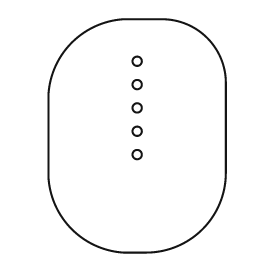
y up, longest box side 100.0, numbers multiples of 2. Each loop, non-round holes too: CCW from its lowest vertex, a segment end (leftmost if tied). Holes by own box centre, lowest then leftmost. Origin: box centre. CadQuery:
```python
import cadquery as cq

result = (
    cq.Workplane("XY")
    .moveTo(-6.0, -50.0)
    .lineTo(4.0, -50.0)
    .threePointArc((28.0, -40.0), (38.0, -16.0))
    .lineTo(38.0, 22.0)
    .threePointArc((30.0, 42.0), (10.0, 50.0))
    .lineTo(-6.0, 50.0)
    .threePointArc((-28.0, 40.0), (-38.0, 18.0))
    .lineTo(-38.0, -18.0)
    .threePointArc((-28.0, -40.0), (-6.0, -50.0))
    .close()
    .moveTo(0.0, -8.0)
    .circle(2.0)
    .moveTo(0.0, 2.0)
    .circle(2.0)
    .moveTo(0.0, 12.0)
    .circle(2.0)
    .moveTo(0.0, 22.0)
    .circle(2.0)
    .moveTo(0.0, 32.0)
    .circle(2.0)
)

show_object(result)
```